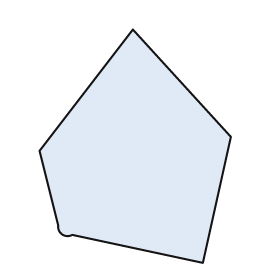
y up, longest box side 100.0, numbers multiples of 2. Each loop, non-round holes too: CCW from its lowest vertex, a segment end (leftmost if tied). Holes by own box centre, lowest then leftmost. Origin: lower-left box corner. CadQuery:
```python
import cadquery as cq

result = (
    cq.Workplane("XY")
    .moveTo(70.0, 0.0)
    .lineTo(82.0, 54.0)
    .lineTo(40.0, 100.0)
    .lineTo(0.0, 48.0)
    .lineTo(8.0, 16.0)
    .threePointArc((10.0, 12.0), (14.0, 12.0))
    .close()
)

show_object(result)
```